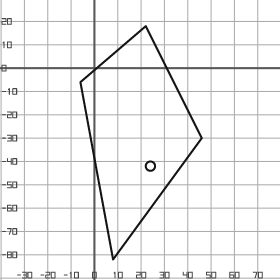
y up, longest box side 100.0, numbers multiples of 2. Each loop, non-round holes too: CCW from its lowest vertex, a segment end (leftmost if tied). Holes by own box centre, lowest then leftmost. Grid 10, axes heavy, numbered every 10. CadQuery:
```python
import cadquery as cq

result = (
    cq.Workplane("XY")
    .moveTo(8.0, -82.0)
    .lineTo(46.0, -30.0)
    .lineTo(22.0, 18.0)
    .lineTo(-6.0, -6.0)
    .close()
    .moveTo(24.0, -42.0)
    .circle(2.0)
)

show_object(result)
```